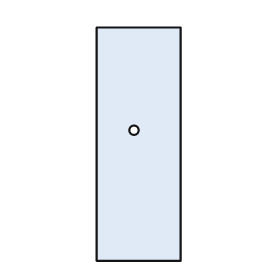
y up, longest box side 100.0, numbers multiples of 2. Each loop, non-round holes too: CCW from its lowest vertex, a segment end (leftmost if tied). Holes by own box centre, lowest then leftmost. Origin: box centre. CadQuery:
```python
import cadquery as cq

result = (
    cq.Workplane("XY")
    .moveTo(-18.0, -50.0)
    .lineTo(18.0, -50.0)
    .lineTo(18.0, 50.0)
    .lineTo(-18.0, 50.0)
    .close()
    .moveTo(-2.0, 6.0)
    .circle(2.0)
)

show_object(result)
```